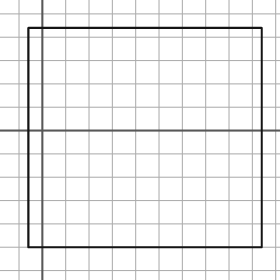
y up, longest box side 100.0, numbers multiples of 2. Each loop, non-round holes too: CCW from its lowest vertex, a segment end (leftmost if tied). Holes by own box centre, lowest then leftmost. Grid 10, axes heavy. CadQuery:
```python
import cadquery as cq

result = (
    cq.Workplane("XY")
    .moveTo(-6.0, -50.0)
    .lineTo(94.0, -50.0)
    .lineTo(94.0, 44.0)
    .lineTo(-6.0, 44.0)
    .close()
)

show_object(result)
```